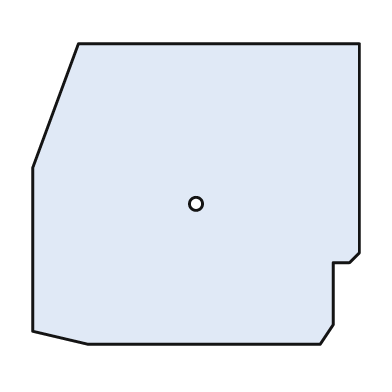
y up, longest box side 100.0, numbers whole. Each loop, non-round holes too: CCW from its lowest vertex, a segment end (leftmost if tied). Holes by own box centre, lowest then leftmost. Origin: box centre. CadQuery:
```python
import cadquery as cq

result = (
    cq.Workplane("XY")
    .moveTo(-33.0, -46.0)
    .lineTo(38.0, -46.0)
    .lineTo(42.0, -40.0)
    .lineTo(42.0, -21.0)
    .lineTo(47.0, -21.0)
    .lineTo(50.0, -18.0)
    .lineTo(50.0, 46.0)
    .lineTo(-36.0, 46.0)
    .lineTo(-50.0, 8.0)
    .lineTo(-50.0, -42.0)
    .close()
    .moveTo(0.0, -3.0)
    .circle(2.0)
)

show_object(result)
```